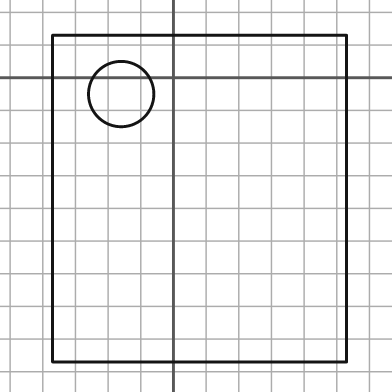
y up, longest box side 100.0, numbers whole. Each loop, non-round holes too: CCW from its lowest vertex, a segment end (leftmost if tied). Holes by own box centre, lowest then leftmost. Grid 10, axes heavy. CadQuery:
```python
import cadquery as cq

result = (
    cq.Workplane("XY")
    .moveTo(-37.0, -87.0)
    .lineTo(53.0, -87.0)
    .lineTo(53.0, 13.0)
    .lineTo(-37.0, 13.0)
    .close()
    .moveTo(-16.0, -5.0)
    .circle(10.0)
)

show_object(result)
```